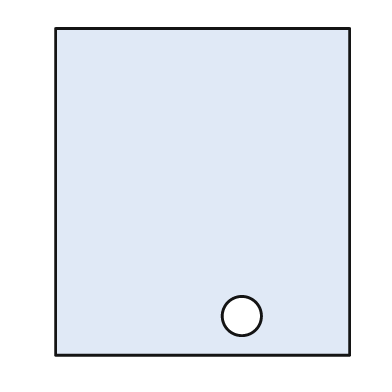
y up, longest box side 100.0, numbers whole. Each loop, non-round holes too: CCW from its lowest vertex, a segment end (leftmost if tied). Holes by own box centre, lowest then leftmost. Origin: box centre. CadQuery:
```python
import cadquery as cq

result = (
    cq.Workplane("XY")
    .moveTo(-45.0, -50.0)
    .lineTo(45.0, -50.0)
    .lineTo(45.0, 50.0)
    .lineTo(-45.0, 50.0)
    .close()
    .moveTo(12.0, -38.0)
    .circle(6.0)
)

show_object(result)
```